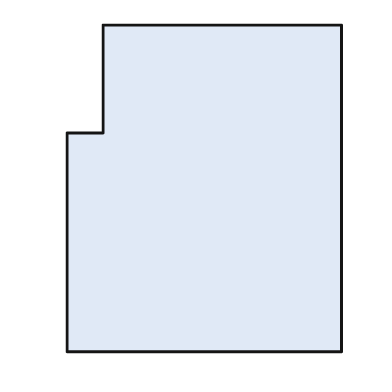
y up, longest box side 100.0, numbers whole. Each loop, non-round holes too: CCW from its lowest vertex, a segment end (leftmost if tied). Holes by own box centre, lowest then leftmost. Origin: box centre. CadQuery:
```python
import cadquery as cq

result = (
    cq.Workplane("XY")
    .moveTo(-42.0, -50.0)
    .lineTo(42.0, -50.0)
    .lineTo(42.0, 50.0)
    .lineTo(-31.0, 50.0)
    .lineTo(-31.0, 17.0)
    .lineTo(-42.0, 17.0)
    .close()
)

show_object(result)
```